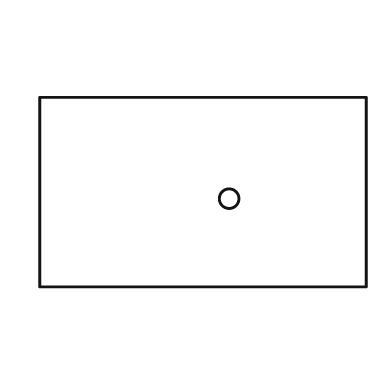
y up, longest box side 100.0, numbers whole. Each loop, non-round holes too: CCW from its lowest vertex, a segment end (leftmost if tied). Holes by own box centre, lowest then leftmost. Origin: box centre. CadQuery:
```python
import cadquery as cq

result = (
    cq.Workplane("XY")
    .moveTo(-50.0, -29.0)
    .lineTo(50.0, -29.0)
    .lineTo(50.0, 29.0)
    .lineTo(-50.0, 29.0)
    .close()
    .moveTo(8.0, -2.0)
    .circle(3.0)
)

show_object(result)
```